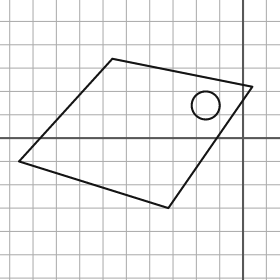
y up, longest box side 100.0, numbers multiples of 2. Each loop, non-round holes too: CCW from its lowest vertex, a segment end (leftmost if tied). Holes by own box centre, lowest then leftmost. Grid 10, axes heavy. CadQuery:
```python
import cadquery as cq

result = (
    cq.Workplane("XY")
    .moveTo(-32.0, -30.0)
    .lineTo(4.0, 22.0)
    .lineTo(-56.0, 34.0)
    .lineTo(-96.0, -10.0)
    .close()
    .moveTo(-16.0, 14.0)
    .circle(6.0)
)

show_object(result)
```